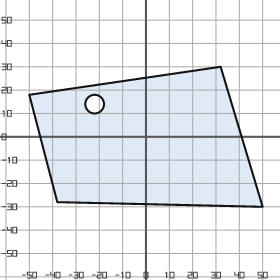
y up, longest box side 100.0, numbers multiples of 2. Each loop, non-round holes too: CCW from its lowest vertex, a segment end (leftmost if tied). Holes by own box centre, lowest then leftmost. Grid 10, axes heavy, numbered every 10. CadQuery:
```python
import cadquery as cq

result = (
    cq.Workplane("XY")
    .moveTo(50.0, -30.0)
    .lineTo(32.0, 30.0)
    .lineTo(-50.0, 18.0)
    .lineTo(-38.0, -28.0)
    .close()
    .moveTo(-22.0, 14.0)
    .circle(4.0)
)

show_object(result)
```